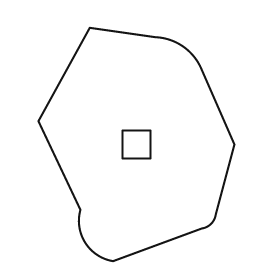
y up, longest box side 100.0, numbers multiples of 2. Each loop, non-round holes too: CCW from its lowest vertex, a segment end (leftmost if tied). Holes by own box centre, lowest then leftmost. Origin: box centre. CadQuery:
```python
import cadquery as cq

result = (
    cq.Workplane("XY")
    .moveTo(-10.0, -50.0)
    .lineTo(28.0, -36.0)
    .threePointArc((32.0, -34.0), (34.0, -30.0))
    .lineTo(42.0, 0.0)
    .lineTo(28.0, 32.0)
    .threePointArc((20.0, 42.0), (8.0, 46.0))
    .lineTo(-20.0, 50.0)
    .lineTo(-42.0, 10.0)
    .lineTo(-24.0, -28.0)
    .threePointArc((-22.0, -42.0), (-10.0, -50.0))
    .close()
    .moveTo(-6.0, -6.0)
    .lineTo(6.0, -6.0)
    .lineTo(6.0, 6.0)
    .lineTo(-6.0, 6.0)
    .close()
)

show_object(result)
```